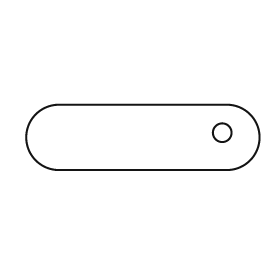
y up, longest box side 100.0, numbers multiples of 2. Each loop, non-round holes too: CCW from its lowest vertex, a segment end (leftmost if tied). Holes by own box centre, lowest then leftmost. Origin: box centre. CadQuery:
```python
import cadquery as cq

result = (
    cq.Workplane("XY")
    .moveTo(-36.0, -14.0)
    .lineTo(36.0, -14.0)
    .threePointArc((50.0, 0.0), (36.0, 14.0))
    .lineTo(-36.0, 14.0)
    .threePointArc((-50.0, 0.0), (-36.0, -14.0))
    .close()
    .moveTo(34.0, 2.0)
    .circle(4.0)
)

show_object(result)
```